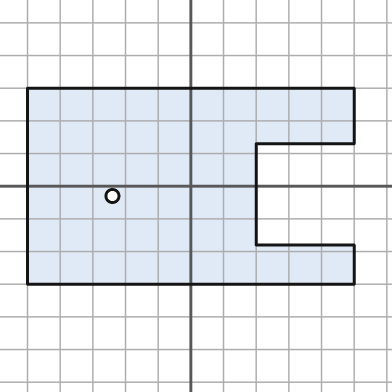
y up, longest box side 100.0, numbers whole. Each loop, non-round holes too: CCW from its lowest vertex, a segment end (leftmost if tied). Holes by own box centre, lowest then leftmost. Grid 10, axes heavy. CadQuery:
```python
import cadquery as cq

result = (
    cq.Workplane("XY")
    .moveTo(-50.0, -30.0)
    .lineTo(50.0, -30.0)
    .lineTo(50.0, -18.0)
    .lineTo(20.0, -18.0)
    .lineTo(20.0, 13.0)
    .lineTo(50.0, 13.0)
    .lineTo(50.0, 30.0)
    .lineTo(-50.0, 30.0)
    .close()
    .moveTo(-24.0, -3.0)
    .circle(2.0)
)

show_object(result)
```